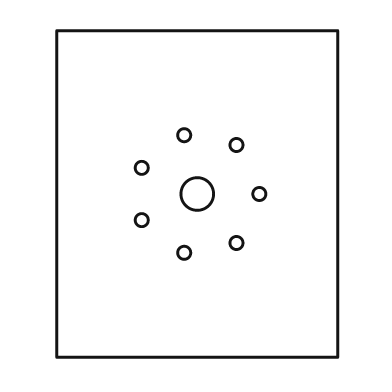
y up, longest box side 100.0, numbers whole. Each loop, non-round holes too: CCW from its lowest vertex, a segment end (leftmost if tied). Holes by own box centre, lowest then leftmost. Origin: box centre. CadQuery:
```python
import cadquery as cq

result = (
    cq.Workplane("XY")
    .moveTo(-43.0, -50.0)
    .lineTo(43.0, -50.0)
    .lineTo(43.0, 50.0)
    .lineTo(-43.0, 50.0)
    .close()
    .moveTo(-4.0, -18.0)
    .circle(2.0)
    .moveTo(12.0, -15.0)
    .circle(2.0)
    .moveTo(-17.0, -8.0)
    .circle(2.0)
    .moveTo(0.0, 0.0)
    .circle(5.0)
    .moveTo(19.0, 0.0)
    .circle(2.0)
    .moveTo(-17.0, 8.0)
    .circle(2.0)
    .moveTo(12.0, 15.0)
    .circle(2.0)
    .moveTo(-4.0, 18.0)
    .circle(2.0)
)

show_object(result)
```